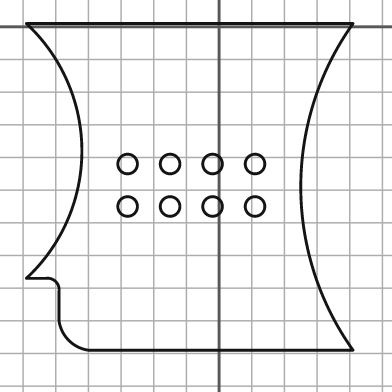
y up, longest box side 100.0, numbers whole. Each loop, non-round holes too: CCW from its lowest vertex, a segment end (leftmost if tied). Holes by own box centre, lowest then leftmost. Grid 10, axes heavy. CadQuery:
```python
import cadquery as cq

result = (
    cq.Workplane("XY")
    .moveTo(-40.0, -99.0)
    .lineTo(41.0, -99.0)
    .threePointArc((25.0, -49.0), (41.0, 1.0))
    .lineTo(-59.0, 1.0)
    .threePointArc((-42.0, -38.0), (-59.0, -77.0))
    .lineTo(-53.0, -77.0)
    .threePointArc((-50.0, -78.0), (-49.0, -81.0))
    .lineTo(-49.0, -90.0)
    .threePointArc((-46.0, -96.0), (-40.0, -99.0))
    .close()
    .moveTo(-28.0, -55.0)
    .circle(3.0)
    .moveTo(-15.0, -55.0)
    .circle(3.0)
    .moveTo(-2.0, -55.0)
    .circle(3.0)
    .moveTo(11.0, -55.0)
    .circle(3.0)
    .moveTo(-28.0, -42.0)
    .circle(3.0)
    .moveTo(-15.0, -42.0)
    .circle(3.0)
    .moveTo(-2.0, -42.0)
    .circle(3.0)
    .moveTo(11.0, -42.0)
    .circle(3.0)
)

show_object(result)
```